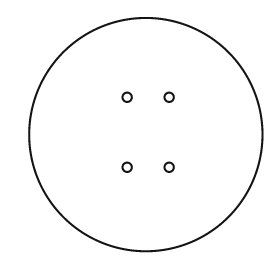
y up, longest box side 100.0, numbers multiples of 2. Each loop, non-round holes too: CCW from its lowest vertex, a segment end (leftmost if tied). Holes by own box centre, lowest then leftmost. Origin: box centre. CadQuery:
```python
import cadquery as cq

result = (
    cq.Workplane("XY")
    .moveTo(0.0, 0.0)
    .circle(50.0)
    .moveTo(-8.0, -14.0)
    .circle(2.0)
    .moveTo(10.0, -14.0)
    .circle(2.0)
    .moveTo(-8.0, 16.0)
    .circle(2.0)
    .moveTo(10.0, 16.0)
    .circle(2.0)
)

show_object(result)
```